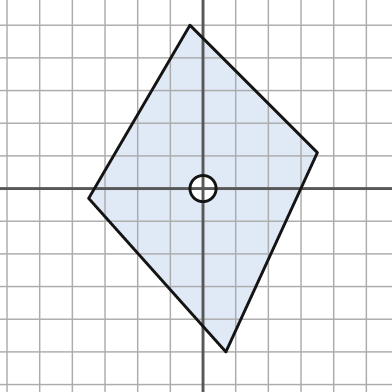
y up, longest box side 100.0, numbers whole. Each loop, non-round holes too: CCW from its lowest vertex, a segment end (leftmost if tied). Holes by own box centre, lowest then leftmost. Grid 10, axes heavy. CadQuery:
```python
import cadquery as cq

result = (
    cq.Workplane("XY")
    .moveTo(7.0, -50.0)
    .lineTo(35.0, 11.0)
    .lineTo(-4.0, 50.0)
    .lineTo(-35.0, -3.0)
    .close()
    .moveTo(0.0, 0.0)
    .circle(4.0)
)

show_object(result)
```